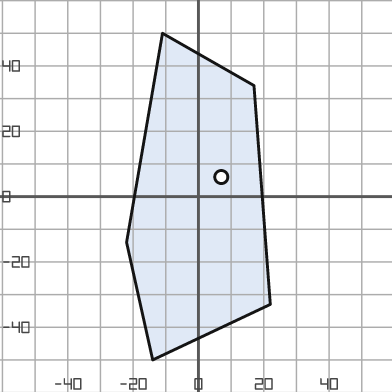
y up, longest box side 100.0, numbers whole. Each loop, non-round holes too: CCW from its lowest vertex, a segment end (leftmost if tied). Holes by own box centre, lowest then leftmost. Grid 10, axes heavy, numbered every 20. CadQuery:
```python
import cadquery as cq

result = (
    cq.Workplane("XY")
    .moveTo(-14.0, -50.0)
    .lineTo(22.0, -33.0)
    .lineTo(17.0, 34.0)
    .lineTo(-11.0, 50.0)
    .lineTo(-22.0, -14.0)
    .close()
    .moveTo(7.0, 6.0)
    .circle(2.0)
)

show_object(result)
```